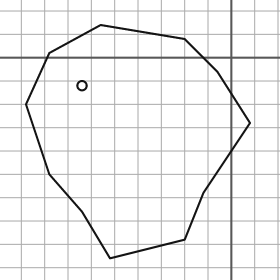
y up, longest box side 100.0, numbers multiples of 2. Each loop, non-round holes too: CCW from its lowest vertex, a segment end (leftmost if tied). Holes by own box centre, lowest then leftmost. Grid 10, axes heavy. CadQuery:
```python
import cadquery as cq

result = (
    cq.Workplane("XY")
    .moveTo(-52.0, -86.0)
    .lineTo(-20.0, -78.0)
    .lineTo(-12.0, -58.0)
    .lineTo(8.0, -28.0)
    .lineTo(-6.0, -6.0)
    .lineTo(-20.0, 8.0)
    .lineTo(-56.0, 14.0)
    .lineTo(-78.0, 2.0)
    .lineTo(-88.0, -20.0)
    .lineTo(-78.0, -50.0)
    .lineTo(-64.0, -66.0)
    .close()
    .moveTo(-64.0, -12.0)
    .circle(2.0)
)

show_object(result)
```